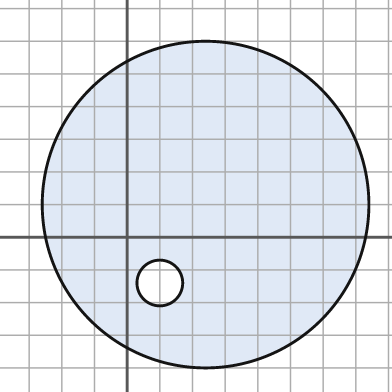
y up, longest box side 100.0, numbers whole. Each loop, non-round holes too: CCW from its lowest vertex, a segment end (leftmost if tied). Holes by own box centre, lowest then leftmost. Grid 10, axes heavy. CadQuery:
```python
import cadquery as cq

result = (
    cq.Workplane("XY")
    .moveTo(24.0, 10.0)
    .circle(50.0)
    .moveTo(10.0, -14.0)
    .circle(7.0)
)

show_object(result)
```